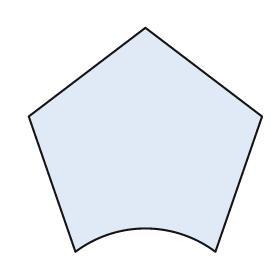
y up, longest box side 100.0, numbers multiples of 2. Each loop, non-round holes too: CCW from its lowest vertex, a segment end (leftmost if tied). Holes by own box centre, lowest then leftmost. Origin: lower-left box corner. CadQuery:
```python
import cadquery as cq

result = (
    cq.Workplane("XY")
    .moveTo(20.0, 0.0)
    .threePointArc((50.0, 10.0), (80.0, 0.0))
    .lineTo(100.0, 58.0)
    .lineTo(50.0, 96.0)
    .lineTo(0.0, 58.0)
    .close()
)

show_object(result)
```